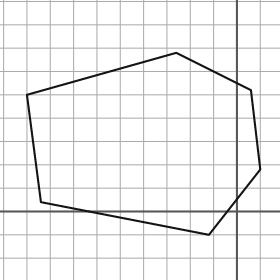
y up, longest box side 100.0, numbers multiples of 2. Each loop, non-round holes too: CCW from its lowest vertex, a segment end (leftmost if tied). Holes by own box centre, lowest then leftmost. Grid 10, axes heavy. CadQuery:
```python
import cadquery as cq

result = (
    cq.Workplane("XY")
    .moveTo(-12.0, -10.0)
    .lineTo(10.0, 18.0)
    .lineTo(6.0, 52.0)
    .lineTo(-26.0, 68.0)
    .lineTo(-90.0, 50.0)
    .lineTo(-84.0, 4.0)
    .close()
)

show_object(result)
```